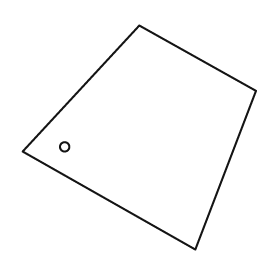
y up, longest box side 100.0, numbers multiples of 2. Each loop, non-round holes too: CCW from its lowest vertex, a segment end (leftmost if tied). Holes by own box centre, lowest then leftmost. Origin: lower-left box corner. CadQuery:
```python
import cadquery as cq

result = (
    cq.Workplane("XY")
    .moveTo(74.0, 0.0)
    .lineTo(100.0, 68.0)
    .lineTo(50.0, 96.0)
    .lineTo(0.0, 42.0)
    .close()
    .moveTo(18.0, 44.0)
    .circle(2.0)
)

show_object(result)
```